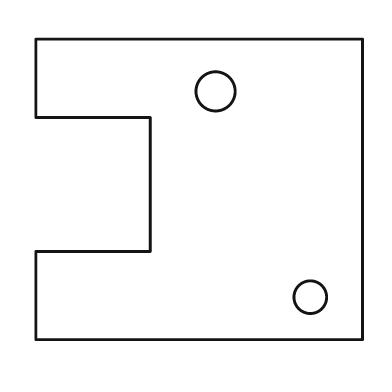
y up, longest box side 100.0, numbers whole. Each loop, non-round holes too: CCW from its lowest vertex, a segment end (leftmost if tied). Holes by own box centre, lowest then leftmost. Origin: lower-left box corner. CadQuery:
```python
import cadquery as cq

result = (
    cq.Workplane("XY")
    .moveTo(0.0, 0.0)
    .lineTo(100.0, 0.0)
    .lineTo(100.0, 92.0)
    .lineTo(0.0, 92.0)
    .lineTo(0.0, 68.0)
    .lineTo(35.0, 68.0)
    .lineTo(35.0, 27.0)
    .lineTo(0.0, 27.0)
    .close()
    .moveTo(84.0, 13.0)
    .circle(5.0)
    .moveTo(55.0, 76.0)
    .circle(6.0)
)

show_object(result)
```